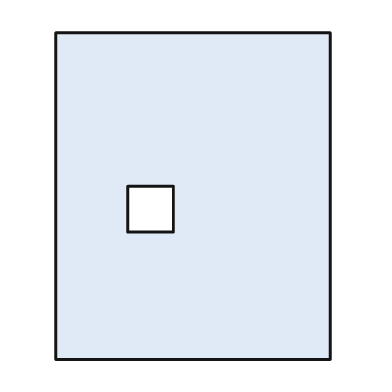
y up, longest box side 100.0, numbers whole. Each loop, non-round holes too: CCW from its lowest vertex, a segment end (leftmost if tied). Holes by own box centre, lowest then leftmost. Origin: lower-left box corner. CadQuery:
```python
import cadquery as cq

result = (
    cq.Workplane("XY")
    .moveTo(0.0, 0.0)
    .lineTo(84.0, 0.0)
    .lineTo(84.0, 100.0)
    .lineTo(0.0, 100.0)
    .close()
    .moveTo(22.0, 39.0)
    .lineTo(36.0, 39.0)
    .lineTo(36.0, 53.0)
    .lineTo(22.0, 53.0)
    .close()
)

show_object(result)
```